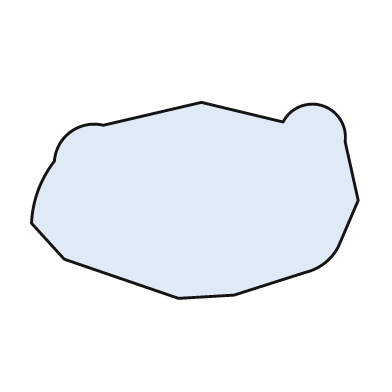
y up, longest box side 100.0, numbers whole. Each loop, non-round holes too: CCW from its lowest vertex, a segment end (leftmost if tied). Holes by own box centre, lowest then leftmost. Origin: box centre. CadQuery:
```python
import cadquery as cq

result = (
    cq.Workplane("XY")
    .moveTo(-5.0, -30.0)
    .lineTo(12.0, -29.0)
    .lineTo(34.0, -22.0)
    .threePointArc((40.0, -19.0), (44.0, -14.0))
    .lineTo(50.0, 0.0)
    .lineTo(46.0, 18.0)
    .threePointArc((39.0, 29.0), (27.0, 24.0))
    .lineTo(2.0, 30.0)
    .lineTo(-28.0, 23.0)
    .threePointArc((-38.0, 21.0), (-43.0, 12.0))
    .threePointArc((-48.0, 3.0), (-50.0, -7.0))
    .lineTo(-40.0, -18.0)
    .close()
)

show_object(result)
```